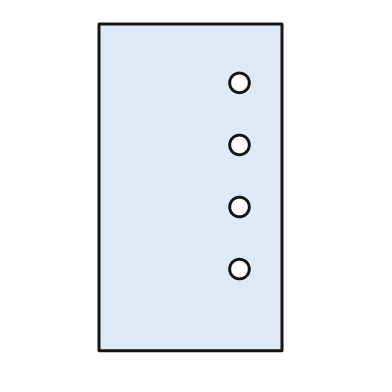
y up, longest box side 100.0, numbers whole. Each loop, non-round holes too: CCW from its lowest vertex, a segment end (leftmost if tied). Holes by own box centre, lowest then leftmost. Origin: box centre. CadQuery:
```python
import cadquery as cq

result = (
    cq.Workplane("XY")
    .moveTo(-28.0, -50.0)
    .lineTo(28.0, -50.0)
    .lineTo(28.0, 50.0)
    .lineTo(-28.0, 50.0)
    .close()
    .moveTo(15.0, -25.0)
    .circle(3.0)
    .moveTo(15.0, -6.0)
    .circle(3.0)
    .moveTo(15.0, 13.0)
    .circle(3.0)
    .moveTo(15.0, 32.0)
    .circle(3.0)
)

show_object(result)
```